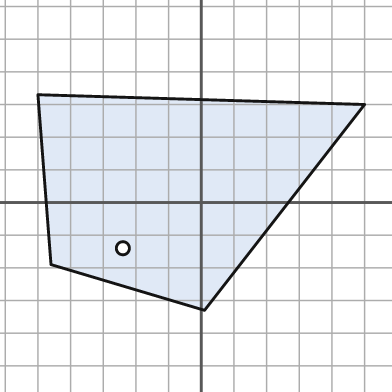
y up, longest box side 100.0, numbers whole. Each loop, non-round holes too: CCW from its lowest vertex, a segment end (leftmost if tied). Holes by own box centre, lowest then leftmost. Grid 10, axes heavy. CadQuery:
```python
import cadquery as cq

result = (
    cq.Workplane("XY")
    .moveTo(1.0, -33.0)
    .lineTo(50.0, 30.0)
    .lineTo(-50.0, 33.0)
    .lineTo(-46.0, -19.0)
    .close()
    .moveTo(-24.0, -14.0)
    .circle(2.0)
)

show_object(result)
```